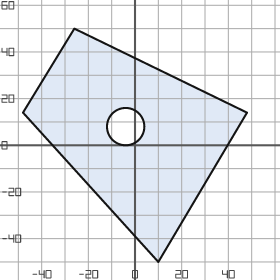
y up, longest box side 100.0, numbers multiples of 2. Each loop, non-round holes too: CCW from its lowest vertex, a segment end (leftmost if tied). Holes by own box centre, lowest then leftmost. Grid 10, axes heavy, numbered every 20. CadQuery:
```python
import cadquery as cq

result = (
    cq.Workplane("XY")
    .moveTo(10.0, -50.0)
    .lineTo(48.0, 14.0)
    .lineTo(-26.0, 50.0)
    .lineTo(-48.0, 14.0)
    .close()
    .moveTo(-4.0, 8.0)
    .circle(8.0)
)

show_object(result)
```